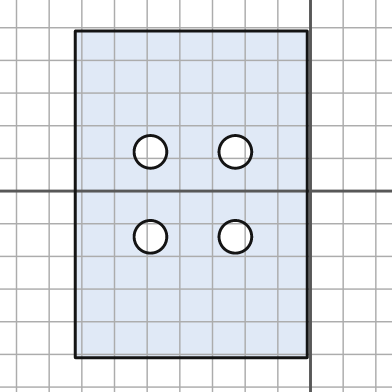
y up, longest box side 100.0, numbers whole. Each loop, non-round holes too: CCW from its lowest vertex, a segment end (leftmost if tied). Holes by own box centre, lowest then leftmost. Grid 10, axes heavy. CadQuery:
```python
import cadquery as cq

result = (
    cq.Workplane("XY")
    .moveTo(-72.0, -51.0)
    .lineTo(-1.0, -51.0)
    .lineTo(-1.0, 49.0)
    .lineTo(-72.0, 49.0)
    .close()
    .moveTo(-49.0, -14.0)
    .circle(5.0)
    .moveTo(-23.0, -14.0)
    .circle(5.0)
    .moveTo(-49.0, 12.0)
    .circle(5.0)
    .moveTo(-23.0, 12.0)
    .circle(5.0)
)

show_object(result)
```